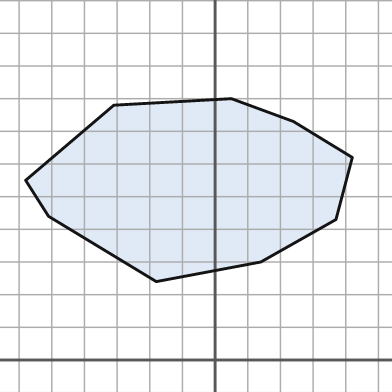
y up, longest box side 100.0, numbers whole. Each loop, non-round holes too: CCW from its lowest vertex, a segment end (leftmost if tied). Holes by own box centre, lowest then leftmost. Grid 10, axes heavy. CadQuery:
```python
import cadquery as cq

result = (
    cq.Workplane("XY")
    .moveTo(-18.0, 24.0)
    .lineTo(14.0, 30.0)
    .lineTo(37.0, 43.0)
    .lineTo(42.0, 62.0)
    .lineTo(24.0, 73.0)
    .lineTo(5.0, 80.0)
    .lineTo(-31.0, 78.0)
    .lineTo(-58.0, 55.0)
    .lineTo(-51.0, 44.0)
    .close()
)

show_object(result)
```